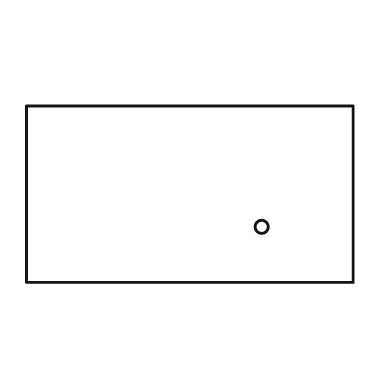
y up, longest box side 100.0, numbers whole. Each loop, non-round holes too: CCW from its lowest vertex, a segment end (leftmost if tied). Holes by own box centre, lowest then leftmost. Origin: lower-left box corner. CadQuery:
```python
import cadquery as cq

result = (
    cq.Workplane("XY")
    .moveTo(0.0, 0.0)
    .lineTo(100.0, 0.0)
    .lineTo(100.0, 54.0)
    .lineTo(0.0, 54.0)
    .close()
    .moveTo(72.0, 17.0)
    .circle(2.0)
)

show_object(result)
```